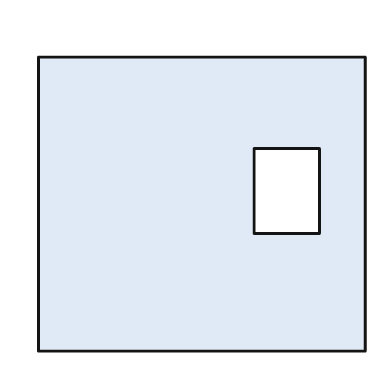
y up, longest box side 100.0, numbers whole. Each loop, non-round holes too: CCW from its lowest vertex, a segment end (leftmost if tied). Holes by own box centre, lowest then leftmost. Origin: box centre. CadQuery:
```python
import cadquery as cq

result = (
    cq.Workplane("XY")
    .moveTo(-50.0, -45.0)
    .lineTo(50.0, -45.0)
    .lineTo(50.0, 45.0)
    .lineTo(-50.0, 45.0)
    .close()
    .moveTo(16.0, -9.0)
    .lineTo(36.0, -9.0)
    .lineTo(36.0, 17.0)
    .lineTo(16.0, 17.0)
    .close()
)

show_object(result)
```